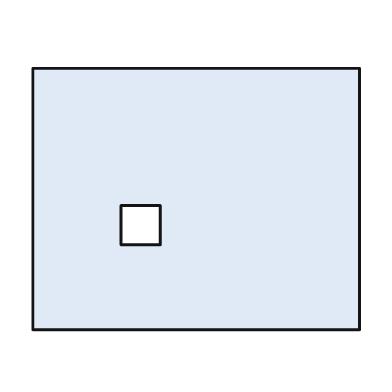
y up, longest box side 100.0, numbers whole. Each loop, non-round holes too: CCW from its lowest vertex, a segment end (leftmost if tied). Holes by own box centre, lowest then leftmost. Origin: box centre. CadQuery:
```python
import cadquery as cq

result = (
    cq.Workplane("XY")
    .moveTo(-50.0, -40.0)
    .lineTo(50.0, -40.0)
    .lineTo(50.0, 40.0)
    .lineTo(-50.0, 40.0)
    .close()
    .moveTo(-23.0, -14.0)
    .lineTo(-11.0, -14.0)
    .lineTo(-11.0, -2.0)
    .lineTo(-23.0, -2.0)
    .close()
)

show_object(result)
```